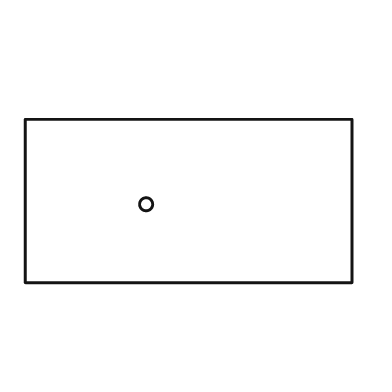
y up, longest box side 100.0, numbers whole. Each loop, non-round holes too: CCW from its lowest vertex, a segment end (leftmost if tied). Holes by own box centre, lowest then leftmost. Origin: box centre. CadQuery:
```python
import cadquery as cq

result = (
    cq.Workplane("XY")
    .moveTo(-50.0, -25.0)
    .lineTo(50.0, -25.0)
    .lineTo(50.0, 25.0)
    .lineTo(-50.0, 25.0)
    .close()
    .moveTo(-13.0, -1.0)
    .circle(2.0)
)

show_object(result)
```